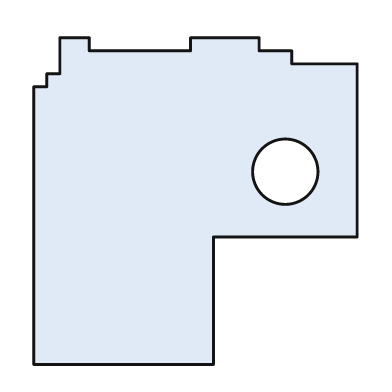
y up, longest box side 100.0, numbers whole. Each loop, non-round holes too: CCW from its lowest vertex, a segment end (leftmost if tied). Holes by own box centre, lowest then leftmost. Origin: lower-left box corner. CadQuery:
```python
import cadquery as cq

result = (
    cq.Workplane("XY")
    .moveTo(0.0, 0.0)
    .lineTo(55.0, 0.0)
    .lineTo(55.0, 39.0)
    .lineTo(99.0, 39.0)
    .lineTo(99.0, 92.0)
    .lineTo(79.0, 92.0)
    .lineTo(79.0, 96.0)
    .lineTo(69.0, 96.0)
    .lineTo(69.0, 100.0)
    .lineTo(48.0, 100.0)
    .lineTo(48.0, 96.0)
    .lineTo(17.0, 96.0)
    .lineTo(17.0, 100.0)
    .lineTo(8.0, 100.0)
    .lineTo(8.0, 89.0)
    .lineTo(4.0, 89.0)
    .lineTo(4.0, 85.0)
    .lineTo(0.0, 85.0)
    .close()
    .moveTo(77.0, 59.0)
    .circle(10.0)
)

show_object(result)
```